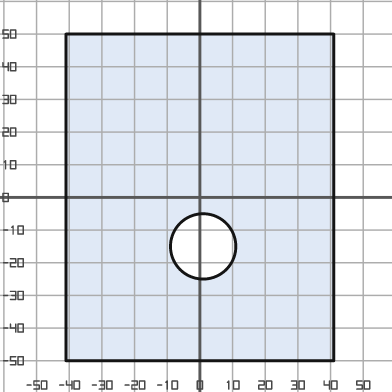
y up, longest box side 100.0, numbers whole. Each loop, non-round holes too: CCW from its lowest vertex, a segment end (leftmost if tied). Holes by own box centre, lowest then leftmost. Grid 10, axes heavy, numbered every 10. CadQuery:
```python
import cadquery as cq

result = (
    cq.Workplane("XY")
    .moveTo(-41.0, -50.0)
    .lineTo(41.0, -50.0)
    .lineTo(41.0, 50.0)
    .lineTo(-41.0, 50.0)
    .close()
    .moveTo(1.0, -15.0)
    .circle(10.0)
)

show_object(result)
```